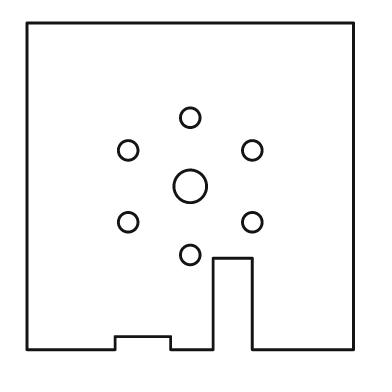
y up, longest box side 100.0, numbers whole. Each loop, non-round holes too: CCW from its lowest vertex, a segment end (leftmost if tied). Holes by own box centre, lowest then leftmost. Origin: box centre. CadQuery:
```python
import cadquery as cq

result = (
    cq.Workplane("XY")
    .moveTo(-50.0, -50.0)
    .lineTo(-23.0, -50.0)
    .lineTo(-23.0, -46.0)
    .lineTo(-6.0, -46.0)
    .lineTo(-6.0, -50.0)
    .lineTo(7.0, -50.0)
    .lineTo(7.0, -22.0)
    .lineTo(19.0, -22.0)
    .lineTo(19.0, -50.0)
    .lineTo(50.0, -50.0)
    .lineTo(50.0, 50.0)
    .lineTo(-50.0, 50.0)
    .close()
    .moveTo(0.0, -21.0)
    .circle(3.0)
    .moveTo(-19.0, -11.0)
    .circle(3.0)
    .moveTo(19.0, -11.0)
    .circle(3.0)
    .moveTo(0.0, 0.0)
    .circle(5.0)
    .moveTo(-19.0, 11.0)
    .circle(3.0)
    .moveTo(19.0, 11.0)
    .circle(3.0)
    .moveTo(0.0, 21.0)
    .circle(3.0)
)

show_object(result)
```